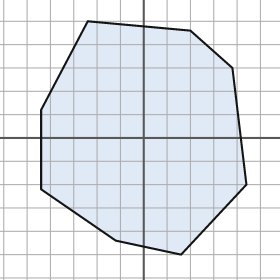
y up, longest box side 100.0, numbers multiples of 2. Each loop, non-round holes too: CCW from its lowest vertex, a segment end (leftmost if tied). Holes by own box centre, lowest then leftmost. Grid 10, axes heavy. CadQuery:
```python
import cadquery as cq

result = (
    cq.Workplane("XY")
    .moveTo(16.0, -50.0)
    .lineTo(44.0, -20.0)
    .lineTo(38.0, 30.0)
    .lineTo(20.0, 46.0)
    .lineTo(-24.0, 50.0)
    .lineTo(-44.0, 12.0)
    .lineTo(-44.0, -22.0)
    .lineTo(-12.0, -44.0)
    .close()
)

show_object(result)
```